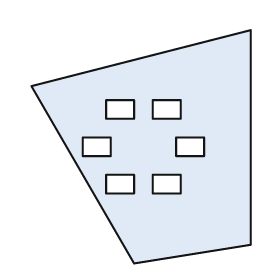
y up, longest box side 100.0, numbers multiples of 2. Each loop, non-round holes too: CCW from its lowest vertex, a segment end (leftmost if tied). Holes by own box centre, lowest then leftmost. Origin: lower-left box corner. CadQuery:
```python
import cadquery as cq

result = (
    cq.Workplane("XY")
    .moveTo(44.0, 0.0)
    .lineTo(94.0, 8.0)
    .lineTo(94.0, 100.0)
    .lineTo(0.0, 76.0)
    .close()
    .moveTo(32.0, 30.0)
    .lineTo(44.0, 30.0)
    .lineTo(44.0, 38.0)
    .lineTo(32.0, 38.0)
    .close()
    .moveTo(52.0, 30.0)
    .lineTo(64.0, 30.0)
    .lineTo(64.0, 38.0)
    .lineTo(52.0, 38.0)
    .close()
    .moveTo(22.0, 46.0)
    .lineTo(34.0, 46.0)
    .lineTo(34.0, 54.0)
    .lineTo(22.0, 54.0)
    .close()
    .moveTo(62.0, 46.0)
    .lineTo(74.0, 46.0)
    .lineTo(74.0, 54.0)
    .lineTo(62.0, 54.0)
    .close()
    .moveTo(32.0, 62.0)
    .lineTo(44.0, 62.0)
    .lineTo(44.0, 70.0)
    .lineTo(32.0, 70.0)
    .close()
    .moveTo(52.0, 62.0)
    .lineTo(64.0, 62.0)
    .lineTo(64.0, 70.0)
    .lineTo(52.0, 70.0)
    .close()
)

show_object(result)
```